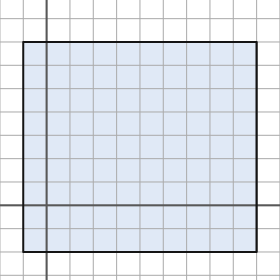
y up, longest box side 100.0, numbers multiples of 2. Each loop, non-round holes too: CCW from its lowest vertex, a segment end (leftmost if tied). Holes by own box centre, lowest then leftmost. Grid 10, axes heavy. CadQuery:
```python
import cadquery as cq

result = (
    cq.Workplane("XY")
    .moveTo(-10.0, -20.0)
    .lineTo(90.0, -20.0)
    .lineTo(90.0, 70.0)
    .lineTo(-10.0, 70.0)
    .close()
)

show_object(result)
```